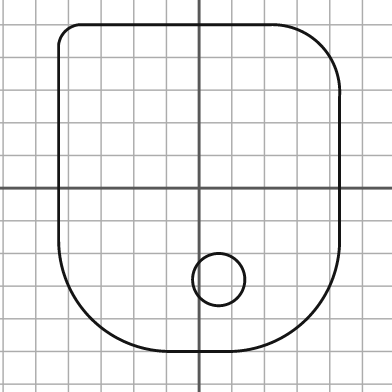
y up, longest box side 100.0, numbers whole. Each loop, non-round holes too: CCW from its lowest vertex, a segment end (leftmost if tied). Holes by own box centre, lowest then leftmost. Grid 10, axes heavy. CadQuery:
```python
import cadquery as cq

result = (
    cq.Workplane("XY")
    .moveTo(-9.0, -50.0)
    .lineTo(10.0, -50.0)
    .threePointArc((33.0, -40.0), (43.0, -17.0))
    .lineTo(43.0, 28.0)
    .threePointArc((37.0, 44.0), (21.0, 50.0))
    .lineTo(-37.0, 50.0)
    .threePointArc((-41.0, 48.0), (-43.0, 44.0))
    .lineTo(-43.0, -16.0)
    .threePointArc((-33.0, -40.0), (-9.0, -50.0))
    .close()
    .moveTo(6.0, -28.0)
    .circle(8.0)
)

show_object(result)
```